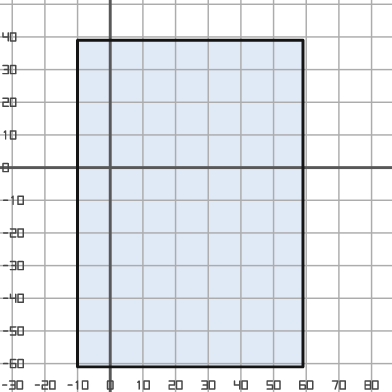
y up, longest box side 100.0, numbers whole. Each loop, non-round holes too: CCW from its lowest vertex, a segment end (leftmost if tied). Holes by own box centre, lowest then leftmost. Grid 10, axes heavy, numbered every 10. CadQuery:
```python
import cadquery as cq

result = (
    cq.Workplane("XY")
    .moveTo(-10.0, -61.0)
    .lineTo(59.0, -61.0)
    .lineTo(59.0, 39.0)
    .lineTo(-10.0, 39.0)
    .close()
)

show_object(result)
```